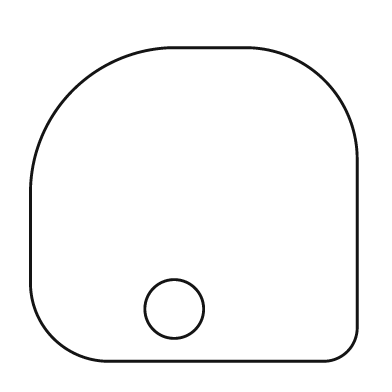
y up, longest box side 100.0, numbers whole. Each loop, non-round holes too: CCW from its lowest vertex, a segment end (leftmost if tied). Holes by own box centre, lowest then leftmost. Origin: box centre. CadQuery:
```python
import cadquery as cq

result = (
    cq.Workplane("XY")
    .moveTo(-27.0, -48.0)
    .lineTo(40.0, -48.0)
    .threePointArc((47.0, -45.0), (50.0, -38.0))
    .lineTo(50.0, 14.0)
    .threePointArc((40.0, 38.0), (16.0, 48.0))
    .lineTo(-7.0, 48.0)
    .threePointArc((-37.0, 35.0), (-50.0, 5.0))
    .lineTo(-50.0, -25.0)
    .threePointArc((-43.0, -41.0), (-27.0, -48.0))
    .close()
    .moveTo(-6.0, -32.0)
    .circle(9.0)
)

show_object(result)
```